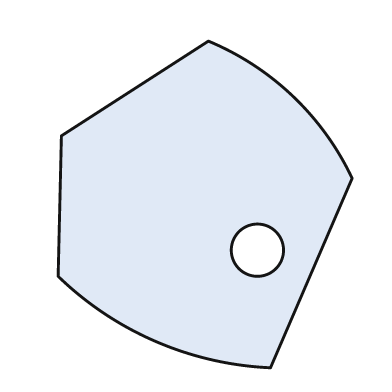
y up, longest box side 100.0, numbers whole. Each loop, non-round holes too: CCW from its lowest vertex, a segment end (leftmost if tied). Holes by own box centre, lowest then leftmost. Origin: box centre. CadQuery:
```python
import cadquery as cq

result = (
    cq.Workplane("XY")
    .moveTo(20.0, -50.0)
    .lineTo(45.0, 8.0)
    .threePointArc((27.0, 33.0), (1.0, 50.0))
    .lineTo(-44.0, 21.0)
    .lineTo(-45.0, -22.0)
    .threePointArc((-15.0, -42.0), (20.0, -50.0))
    .close()
    .moveTo(16.0, -14.0)
    .circle(8.0)
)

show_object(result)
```